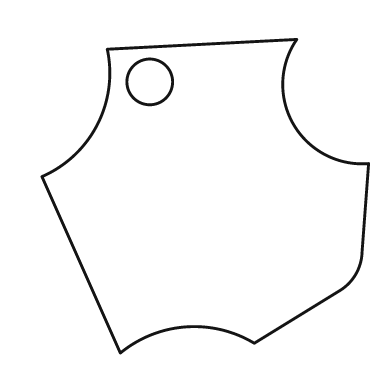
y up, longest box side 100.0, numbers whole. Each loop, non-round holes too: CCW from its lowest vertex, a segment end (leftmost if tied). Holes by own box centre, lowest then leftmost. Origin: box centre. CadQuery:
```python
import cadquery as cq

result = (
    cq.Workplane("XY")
    .moveTo(-26.0, -48.0)
    .threePointArc((-6.0, -40.0), (15.0, -45.0))
    .lineTo(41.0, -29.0)
    .threePointArc((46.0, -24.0), (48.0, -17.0))
    .lineTo(50.0, 10.0)
    .threePointArc((27.0, 22.0), (28.0, 48.0))
    .lineTo(-30.0, 45.0)
    .threePointArc((-33.0, 22.0), (-50.0, 6.0))
    .close()
    .moveTo(-17.0, 35.0)
    .circle(7.0)
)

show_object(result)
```